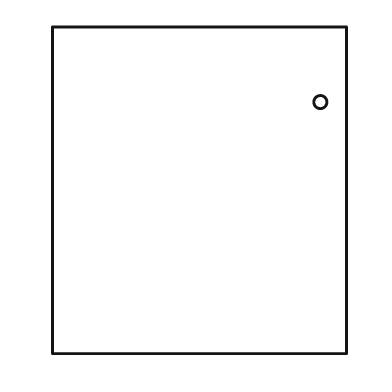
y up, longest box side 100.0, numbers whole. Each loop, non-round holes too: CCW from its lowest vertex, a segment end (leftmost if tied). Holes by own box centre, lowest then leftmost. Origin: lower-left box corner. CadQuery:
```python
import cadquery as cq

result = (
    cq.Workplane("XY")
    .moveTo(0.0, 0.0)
    .lineTo(90.0, 0.0)
    .lineTo(90.0, 100.0)
    .lineTo(0.0, 100.0)
    .close()
    .moveTo(82.0, 77.0)
    .circle(2.0)
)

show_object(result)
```